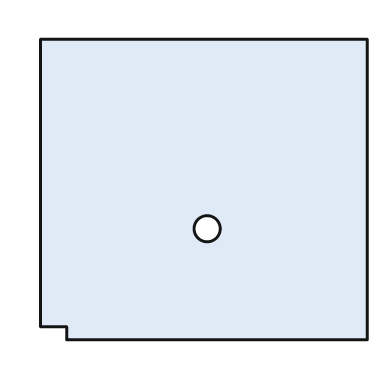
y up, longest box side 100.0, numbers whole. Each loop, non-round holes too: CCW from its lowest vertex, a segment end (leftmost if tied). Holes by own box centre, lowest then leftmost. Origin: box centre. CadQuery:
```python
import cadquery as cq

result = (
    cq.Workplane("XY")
    .moveTo(-42.0, -46.0)
    .lineTo(50.0, -46.0)
    .lineTo(50.0, 46.0)
    .lineTo(-50.0, 46.0)
    .lineTo(-50.0, -42.0)
    .lineTo(-42.0, -42.0)
    .close()
    .moveTo(1.0, -12.0)
    .circle(4.0)
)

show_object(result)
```